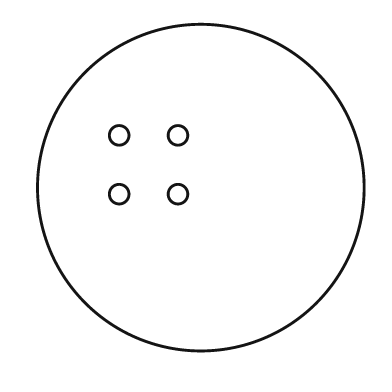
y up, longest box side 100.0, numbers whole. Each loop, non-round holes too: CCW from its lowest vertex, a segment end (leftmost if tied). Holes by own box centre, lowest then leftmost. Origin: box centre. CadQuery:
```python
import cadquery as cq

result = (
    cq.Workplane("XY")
    .moveTo(0.0, 0.0)
    .circle(50.0)
    .moveTo(-25.0, -2.0)
    .circle(3.0)
    .moveTo(-7.0, -2.0)
    .circle(3.0)
    .moveTo(-25.0, 16.0)
    .circle(3.0)
    .moveTo(-7.0, 16.0)
    .circle(3.0)
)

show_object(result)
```